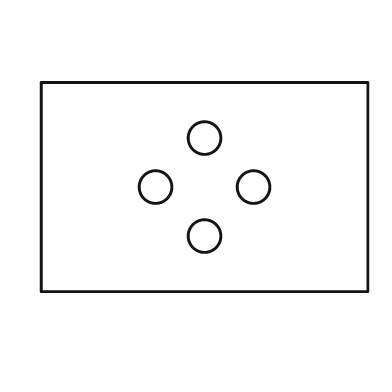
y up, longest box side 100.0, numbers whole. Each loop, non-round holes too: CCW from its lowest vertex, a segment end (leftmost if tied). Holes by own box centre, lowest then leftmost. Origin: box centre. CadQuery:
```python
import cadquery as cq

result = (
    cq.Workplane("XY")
    .moveTo(-50.0, -32.0)
    .lineTo(50.0, -32.0)
    .lineTo(50.0, 32.0)
    .lineTo(-50.0, 32.0)
    .close()
    .moveTo(0.0, -15.0)
    .circle(5.0)
    .moveTo(-15.0, 0.0)
    .circle(5.0)
    .moveTo(15.0, 0.0)
    .circle(5.0)
    .moveTo(0.0, 15.0)
    .circle(5.0)
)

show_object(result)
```